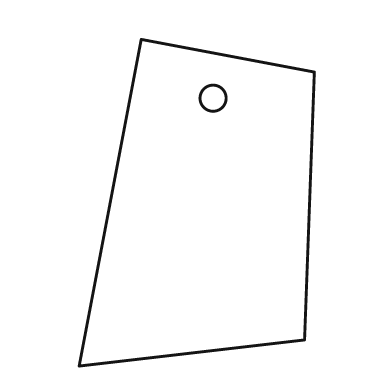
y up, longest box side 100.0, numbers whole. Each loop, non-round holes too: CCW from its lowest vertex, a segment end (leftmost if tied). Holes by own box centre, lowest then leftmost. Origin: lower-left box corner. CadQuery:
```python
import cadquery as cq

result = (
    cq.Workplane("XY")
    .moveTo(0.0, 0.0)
    .lineTo(69.0, 8.0)
    .lineTo(72.0, 90.0)
    .lineTo(19.0, 100.0)
    .close()
    .moveTo(41.0, 82.0)
    .circle(4.0)
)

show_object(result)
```